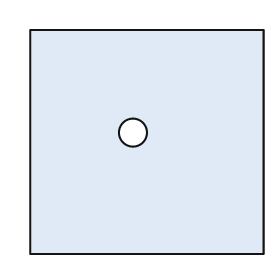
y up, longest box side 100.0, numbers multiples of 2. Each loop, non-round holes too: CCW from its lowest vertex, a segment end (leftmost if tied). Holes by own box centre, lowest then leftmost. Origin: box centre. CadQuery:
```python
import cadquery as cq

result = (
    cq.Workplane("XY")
    .moveTo(-50.0, -48.0)
    .lineTo(50.0, -48.0)
    .lineTo(50.0, 48.0)
    .lineTo(-50.0, 48.0)
    .close()
    .moveTo(-6.0, 4.0)
    .circle(6.0)
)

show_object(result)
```